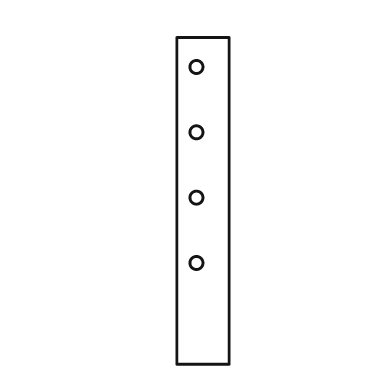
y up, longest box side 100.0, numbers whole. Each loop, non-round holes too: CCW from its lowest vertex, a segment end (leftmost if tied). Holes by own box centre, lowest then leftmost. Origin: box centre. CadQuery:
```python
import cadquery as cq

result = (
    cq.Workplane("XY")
    .moveTo(-8.0, -50.0)
    .lineTo(8.0, -50.0)
    .lineTo(8.0, 50.0)
    .lineTo(-8.0, 50.0)
    .close()
    .moveTo(-2.0, -19.0)
    .circle(2.0)
    .moveTo(-2.0, 1.0)
    .circle(2.0)
    .moveTo(-2.0, 21.0)
    .circle(2.0)
    .moveTo(-2.0, 41.0)
    .circle(2.0)
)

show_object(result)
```